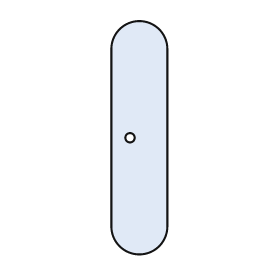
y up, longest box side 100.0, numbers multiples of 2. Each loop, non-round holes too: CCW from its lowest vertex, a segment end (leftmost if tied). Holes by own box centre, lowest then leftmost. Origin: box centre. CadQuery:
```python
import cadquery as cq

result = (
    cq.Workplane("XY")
    .moveTo(-12.0, -38.0)
    .threePointArc((0.0, -50.0), (12.0, -38.0))
    .lineTo(12.0, 38.0)
    .threePointArc((0.0, 50.0), (-12.0, 38.0))
    .close()
    .moveTo(-4.0, 0.0)
    .circle(2.0)
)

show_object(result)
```